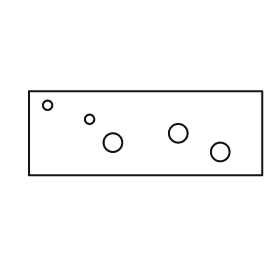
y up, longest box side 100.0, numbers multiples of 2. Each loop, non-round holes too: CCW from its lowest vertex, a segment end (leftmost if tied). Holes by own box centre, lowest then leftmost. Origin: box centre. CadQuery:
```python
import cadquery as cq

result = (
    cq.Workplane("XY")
    .moveTo(-50.0, -18.0)
    .lineTo(50.0, -18.0)
    .lineTo(50.0, 18.0)
    .lineTo(-50.0, 18.0)
    .close()
    .moveTo(32.0, -8.0)
    .circle(4.0)
    .moveTo(-14.0, -4.0)
    .circle(4.0)
    .moveTo(14.0, 0.0)
    .circle(4.0)
    .moveTo(-24.0, 6.0)
    .circle(2.0)
    .moveTo(-42.0, 12.0)
    .circle(2.0)
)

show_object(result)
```